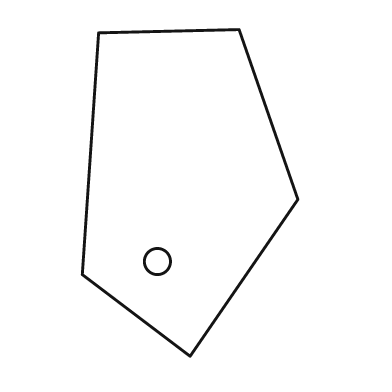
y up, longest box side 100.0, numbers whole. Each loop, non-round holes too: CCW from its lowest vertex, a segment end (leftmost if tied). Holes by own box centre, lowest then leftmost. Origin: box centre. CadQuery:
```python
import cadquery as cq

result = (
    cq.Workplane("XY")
    .moveTo(0.0, -50.0)
    .lineTo(33.0, -2.0)
    .lineTo(15.0, 50.0)
    .lineTo(-28.0, 49.0)
    .lineTo(-33.0, -25.0)
    .close()
    .moveTo(-10.0, -21.0)
    .circle(4.0)
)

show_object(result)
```